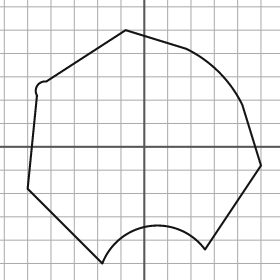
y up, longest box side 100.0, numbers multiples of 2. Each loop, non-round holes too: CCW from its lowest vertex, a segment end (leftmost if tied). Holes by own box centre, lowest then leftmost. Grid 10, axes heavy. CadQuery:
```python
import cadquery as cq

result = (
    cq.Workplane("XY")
    .moveTo(-18.0, -50.0)
    .threePointArc((2.0, -34.0), (26.0, -44.0))
    .lineTo(50.0, -8.0)
    .lineTo(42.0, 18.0)
    .threePointArc((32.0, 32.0), (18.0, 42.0))
    .lineTo(-8.0, 50.0)
    .lineTo(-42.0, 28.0)
    .threePointArc((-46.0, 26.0), (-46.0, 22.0))
    .lineTo(-50.0, -18.0)
    .close()
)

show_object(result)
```